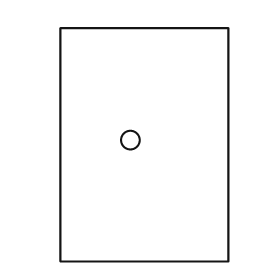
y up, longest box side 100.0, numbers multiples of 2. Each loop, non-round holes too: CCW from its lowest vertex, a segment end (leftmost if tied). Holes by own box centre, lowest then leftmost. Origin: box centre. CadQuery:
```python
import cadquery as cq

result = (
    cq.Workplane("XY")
    .moveTo(-36.0, -50.0)
    .lineTo(36.0, -50.0)
    .lineTo(36.0, 50.0)
    .lineTo(-36.0, 50.0)
    .close()
    .moveTo(-6.0, 2.0)
    .circle(4.0)
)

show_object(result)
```